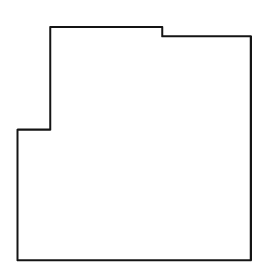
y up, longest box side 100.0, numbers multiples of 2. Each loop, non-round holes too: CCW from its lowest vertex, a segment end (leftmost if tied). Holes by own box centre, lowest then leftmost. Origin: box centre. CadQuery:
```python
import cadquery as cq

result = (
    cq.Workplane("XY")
    .moveTo(-50.0, -50.0)
    .lineTo(50.0, -50.0)
    .lineTo(50.0, 46.0)
    .lineTo(12.0, 46.0)
    .lineTo(12.0, 50.0)
    .lineTo(-36.0, 50.0)
    .lineTo(-36.0, 6.0)
    .lineTo(-50.0, 6.0)
    .close()
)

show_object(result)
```